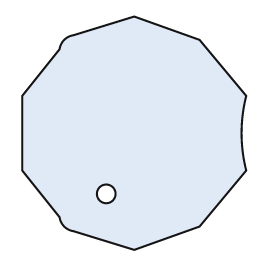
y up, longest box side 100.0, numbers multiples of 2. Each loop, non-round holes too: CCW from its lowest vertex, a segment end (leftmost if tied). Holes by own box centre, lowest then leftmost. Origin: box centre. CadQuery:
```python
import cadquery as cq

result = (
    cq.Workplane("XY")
    .moveTo(0.0, -50.0)
    .lineTo(28.0, -40.0)
    .lineTo(48.0, -16.0)
    .threePointArc((46.0, 0.0), (48.0, 16.0))
    .lineTo(28.0, 40.0)
    .lineTo(0.0, 50.0)
    .lineTo(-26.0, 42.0)
    .threePointArc((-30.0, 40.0), (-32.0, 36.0))
    .lineTo(-48.0, 16.0)
    .lineTo(-48.0, -16.0)
    .lineTo(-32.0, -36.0)
    .threePointArc((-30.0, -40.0), (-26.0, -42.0))
    .close()
    .moveTo(-12.0, -26.0)
    .circle(4.0)
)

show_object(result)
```